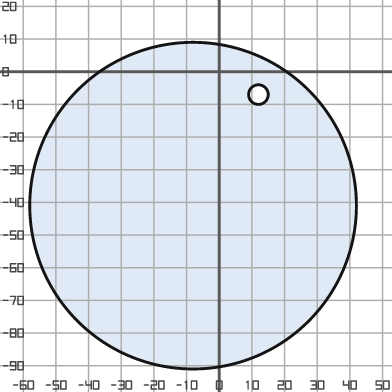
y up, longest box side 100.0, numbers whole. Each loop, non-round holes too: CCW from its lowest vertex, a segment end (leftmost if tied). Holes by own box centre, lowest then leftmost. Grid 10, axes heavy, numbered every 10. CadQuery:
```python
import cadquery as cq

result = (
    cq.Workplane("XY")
    .moveTo(-8.0, -41.0)
    .circle(50.0)
    .moveTo(12.0, -7.0)
    .circle(3.0)
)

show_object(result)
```